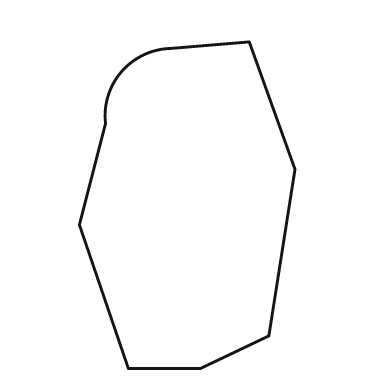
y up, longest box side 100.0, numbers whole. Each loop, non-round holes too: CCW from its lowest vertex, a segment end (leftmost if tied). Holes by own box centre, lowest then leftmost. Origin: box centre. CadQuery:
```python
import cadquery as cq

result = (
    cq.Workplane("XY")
    .moveTo(-18.0, -50.0)
    .lineTo(4.0, -50.0)
    .lineTo(25.0, -40.0)
    .lineTo(33.0, 11.0)
    .lineTo(19.0, 50.0)
    .lineTo(-5.0, 48.0)
    .threePointArc((-20.0, 41.0), (-25.0, 25.0))
    .lineTo(-33.0, -6.0)
    .close()
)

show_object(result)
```